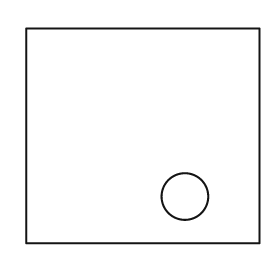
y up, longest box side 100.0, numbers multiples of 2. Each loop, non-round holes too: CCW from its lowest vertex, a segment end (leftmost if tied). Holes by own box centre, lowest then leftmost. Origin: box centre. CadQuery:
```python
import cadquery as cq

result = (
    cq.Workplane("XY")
    .moveTo(-50.0, -46.0)
    .lineTo(50.0, -46.0)
    .lineTo(50.0, 46.0)
    .lineTo(-50.0, 46.0)
    .close()
    .moveTo(18.0, -26.0)
    .circle(10.0)
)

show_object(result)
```